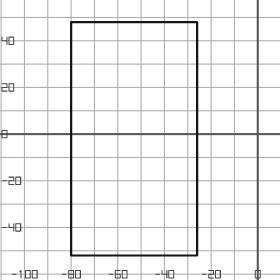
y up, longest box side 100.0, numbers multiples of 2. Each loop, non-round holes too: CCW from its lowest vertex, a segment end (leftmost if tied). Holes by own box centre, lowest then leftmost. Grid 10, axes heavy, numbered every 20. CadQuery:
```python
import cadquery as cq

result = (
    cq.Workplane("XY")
    .moveTo(-80.0, -52.0)
    .lineTo(-26.0, -52.0)
    .lineTo(-26.0, 48.0)
    .lineTo(-80.0, 48.0)
    .close()
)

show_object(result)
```